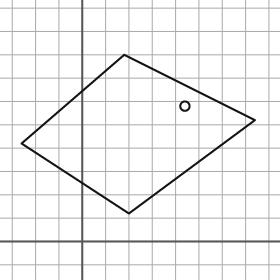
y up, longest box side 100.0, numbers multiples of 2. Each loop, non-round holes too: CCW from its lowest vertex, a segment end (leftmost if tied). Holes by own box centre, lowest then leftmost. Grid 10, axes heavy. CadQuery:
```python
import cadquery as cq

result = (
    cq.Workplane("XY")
    .moveTo(20.0, 12.0)
    .lineTo(74.0, 52.0)
    .lineTo(18.0, 80.0)
    .lineTo(-26.0, 42.0)
    .close()
    .moveTo(44.0, 58.0)
    .circle(2.0)
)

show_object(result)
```